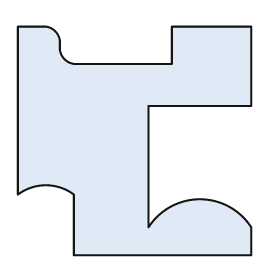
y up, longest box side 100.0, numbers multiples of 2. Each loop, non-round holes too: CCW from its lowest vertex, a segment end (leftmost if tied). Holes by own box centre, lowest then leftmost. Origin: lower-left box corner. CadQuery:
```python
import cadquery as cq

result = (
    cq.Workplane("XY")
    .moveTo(24.0, 0.0)
    .lineTo(100.0, 0.0)
    .lineTo(100.0, 12.0)
    .threePointArc((78.0, 24.0), (56.0, 12.0))
    .lineTo(56.0, 64.0)
    .lineTo(100.0, 64.0)
    .lineTo(100.0, 98.0)
    .lineTo(66.0, 98.0)
    .lineTo(66.0, 82.0)
    .lineTo(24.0, 82.0)
    .threePointArc((20.0, 84.0), (18.0, 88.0))
    .lineTo(18.0, 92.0)
    .threePointArc((16.0, 96.0), (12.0, 98.0))
    .lineTo(0.0, 98.0)
    .lineTo(0.0, 26.0)
    .threePointArc((12.0, 30.0), (24.0, 26.0))
    .close()
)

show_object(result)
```